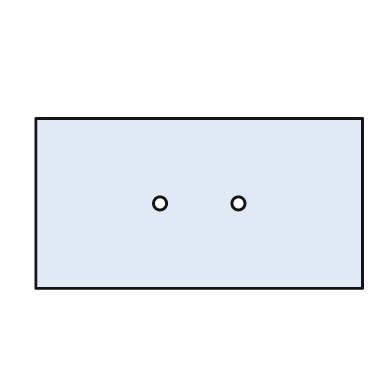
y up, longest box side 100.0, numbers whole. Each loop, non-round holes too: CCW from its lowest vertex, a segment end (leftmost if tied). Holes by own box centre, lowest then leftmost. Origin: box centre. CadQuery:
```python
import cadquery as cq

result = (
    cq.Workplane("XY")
    .moveTo(-50.0, -26.0)
    .lineTo(50.0, -26.0)
    .lineTo(50.0, 26.0)
    .lineTo(-50.0, 26.0)
    .close()
    .moveTo(-12.0, 0.0)
    .circle(2.0)
    .moveTo(12.0, 0.0)
    .circle(2.0)
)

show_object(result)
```